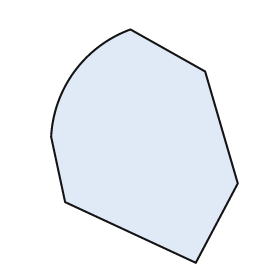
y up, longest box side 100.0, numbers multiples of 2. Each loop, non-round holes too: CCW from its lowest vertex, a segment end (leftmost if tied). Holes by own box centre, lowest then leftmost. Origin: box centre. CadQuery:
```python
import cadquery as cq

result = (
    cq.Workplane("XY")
    .moveTo(22.0, -50.0)
    .lineTo(40.0, -16.0)
    .lineTo(26.0, 32.0)
    .lineTo(-6.0, 50.0)
    .threePointArc((-30.0, 32.0), (-40.0, 4.0))
    .lineTo(-34.0, -24.0)
    .close()
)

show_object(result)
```